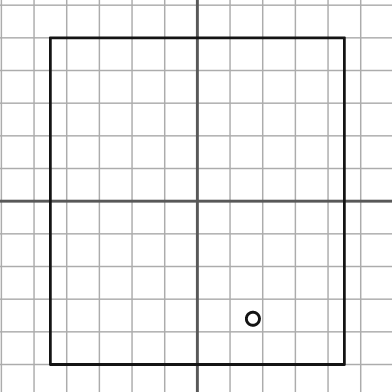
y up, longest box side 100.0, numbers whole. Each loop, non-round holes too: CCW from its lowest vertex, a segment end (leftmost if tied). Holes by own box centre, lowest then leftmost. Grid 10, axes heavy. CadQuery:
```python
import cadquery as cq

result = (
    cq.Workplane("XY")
    .moveTo(-45.0, -50.0)
    .lineTo(45.0, -50.0)
    .lineTo(45.0, 50.0)
    .lineTo(-45.0, 50.0)
    .close()
    .moveTo(17.0, -36.0)
    .circle(2.0)
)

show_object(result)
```